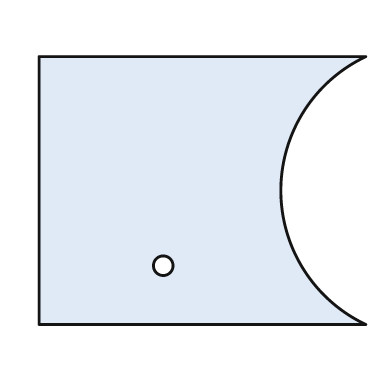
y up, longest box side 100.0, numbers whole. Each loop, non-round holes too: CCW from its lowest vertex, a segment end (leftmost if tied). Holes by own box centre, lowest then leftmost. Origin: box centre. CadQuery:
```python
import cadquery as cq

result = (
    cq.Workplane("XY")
    .moveTo(-50.0, -41.0)
    .lineTo(50.0, -41.0)
    .threePointArc((24.0, 0.0), (50.0, 41.0))
    .lineTo(-50.0, 41.0)
    .close()
    .moveTo(-12.0, -23.0)
    .circle(3.0)
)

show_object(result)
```